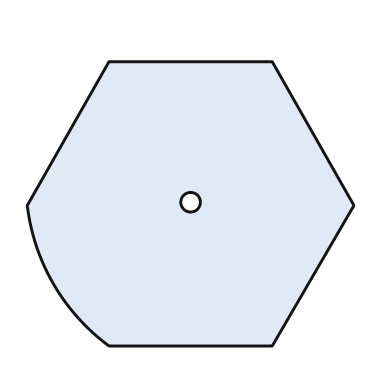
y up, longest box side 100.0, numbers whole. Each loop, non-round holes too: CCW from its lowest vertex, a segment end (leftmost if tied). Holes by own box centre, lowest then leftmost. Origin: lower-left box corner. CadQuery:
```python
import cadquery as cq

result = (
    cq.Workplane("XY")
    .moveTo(25.0, 0.0)
    .lineTo(75.0, 0.0)
    .lineTo(100.0, 43.0)
    .lineTo(75.0, 87.0)
    .lineTo(25.0, 87.0)
    .lineTo(0.0, 43.0)
    .threePointArc((8.0, 19.0), (25.0, 0.0))
    .close()
    .moveTo(50.0, 44.0)
    .circle(3.0)
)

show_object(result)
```